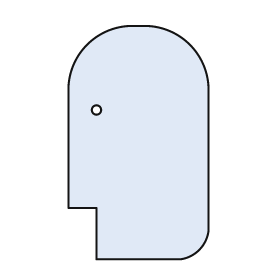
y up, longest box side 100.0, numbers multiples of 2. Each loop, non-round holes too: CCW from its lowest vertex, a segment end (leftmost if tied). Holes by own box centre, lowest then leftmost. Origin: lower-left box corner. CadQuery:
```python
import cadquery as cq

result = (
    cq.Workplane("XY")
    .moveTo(12.0, 0.0)
    .lineTo(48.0, 0.0)
    .threePointArc((56.0, 4.0), (60.0, 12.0))
    .lineTo(60.0, 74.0)
    .threePointArc((52.0, 92.0), (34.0, 100.0))
    .lineTo(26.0, 100.0)
    .threePointArc((8.0, 92.0), (0.0, 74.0))
    .lineTo(0.0, 22.0)
    .lineTo(12.0, 22.0)
    .close()
    .moveTo(12.0, 64.0)
    .circle(2.0)
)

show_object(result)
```